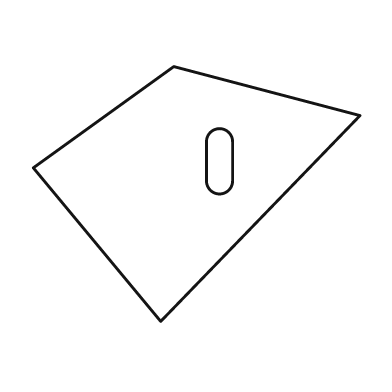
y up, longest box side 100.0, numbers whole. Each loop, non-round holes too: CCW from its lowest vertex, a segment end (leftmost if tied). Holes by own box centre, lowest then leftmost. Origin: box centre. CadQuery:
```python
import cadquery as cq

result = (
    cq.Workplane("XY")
    .moveTo(-11.0, -39.0)
    .lineTo(50.0, 24.0)
    .lineTo(-7.0, 39.0)
    .lineTo(-50.0, 8.0)
    .close()
    .moveTo(3.0, 4.0)
    .threePointArc((7.0, 0.0), (11.0, 4.0))
    .lineTo(11.0, 16.0)
    .threePointArc((7.0, 20.0), (3.0, 16.0))
    .close()
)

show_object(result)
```